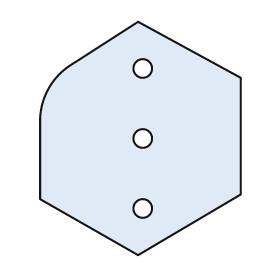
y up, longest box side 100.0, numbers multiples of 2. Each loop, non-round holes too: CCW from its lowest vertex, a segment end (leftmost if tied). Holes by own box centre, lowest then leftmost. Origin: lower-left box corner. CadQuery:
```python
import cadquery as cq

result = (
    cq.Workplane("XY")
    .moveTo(42.0, 0.0)
    .lineTo(86.0, 26.0)
    .lineTo(86.0, 76.0)
    .lineTo(42.0, 100.0)
    .lineTo(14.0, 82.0)
    .threePointArc((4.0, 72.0), (0.0, 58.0))
    .lineTo(0.0, 24.0)
    .close()
    .moveTo(44.0, 20.0)
    .circle(4.0)
    .moveTo(44.0, 50.0)
    .circle(4.0)
    .moveTo(44.0, 80.0)
    .circle(4.0)
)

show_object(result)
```